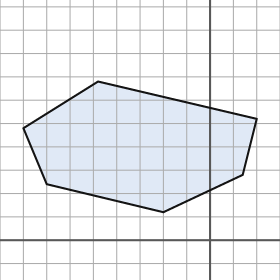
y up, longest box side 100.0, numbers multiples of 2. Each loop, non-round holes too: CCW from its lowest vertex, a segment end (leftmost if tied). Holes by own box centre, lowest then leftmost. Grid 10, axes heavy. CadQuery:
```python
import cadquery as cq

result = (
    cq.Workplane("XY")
    .moveTo(-20.0, 12.0)
    .lineTo(14.0, 28.0)
    .lineTo(20.0, 52.0)
    .lineTo(-48.0, 68.0)
    .lineTo(-80.0, 48.0)
    .lineTo(-70.0, 24.0)
    .close()
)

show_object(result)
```